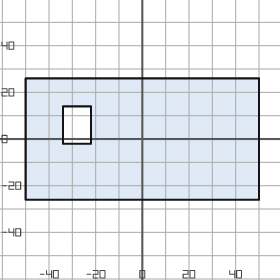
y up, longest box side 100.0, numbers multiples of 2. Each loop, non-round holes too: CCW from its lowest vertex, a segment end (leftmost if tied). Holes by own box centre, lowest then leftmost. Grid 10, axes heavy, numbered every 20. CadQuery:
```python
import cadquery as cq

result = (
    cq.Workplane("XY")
    .moveTo(-50.0, -26.0)
    .lineTo(50.0, -26.0)
    .lineTo(50.0, 26.0)
    .lineTo(-50.0, 26.0)
    .close()
    .moveTo(-34.0, -2.0)
    .lineTo(-22.0, -2.0)
    .lineTo(-22.0, 14.0)
    .lineTo(-34.0, 14.0)
    .close()
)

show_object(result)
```